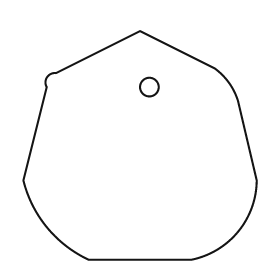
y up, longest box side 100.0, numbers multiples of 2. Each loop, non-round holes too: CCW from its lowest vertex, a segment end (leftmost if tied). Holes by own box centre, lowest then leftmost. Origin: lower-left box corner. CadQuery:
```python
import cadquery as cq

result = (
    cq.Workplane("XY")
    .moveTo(28.0, 0.0)
    .lineTo(72.0, 0.0)
    .threePointArc((92.0, 12.0), (100.0, 34.0))
    .lineTo(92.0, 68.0)
    .threePointArc((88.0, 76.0), (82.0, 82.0))
    .lineTo(50.0, 98.0)
    .lineTo(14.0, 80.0)
    .threePointArc((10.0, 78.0), (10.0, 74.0))
    .lineTo(0.0, 34.0)
    .threePointArc((10.0, 14.0), (28.0, 0.0))
    .close()
    .moveTo(54.0, 74.0)
    .circle(4.0)
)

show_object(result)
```